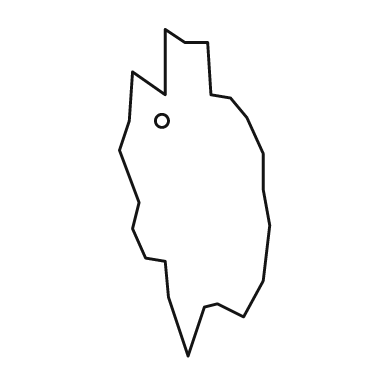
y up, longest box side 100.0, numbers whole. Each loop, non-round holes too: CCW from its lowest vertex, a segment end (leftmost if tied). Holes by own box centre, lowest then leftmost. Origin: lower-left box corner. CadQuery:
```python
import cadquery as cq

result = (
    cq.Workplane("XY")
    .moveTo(21.0, 0.0)
    .lineTo(26.0, 15.0)
    .lineTo(30.0, 16.0)
    .lineTo(38.0, 12.0)
    .lineTo(44.0, 23.0)
    .lineTo(46.0, 40.0)
    .lineTo(44.0, 51.0)
    .lineTo(44.0, 62.0)
    .lineTo(39.0, 73.0)
    .lineTo(34.0, 79.0)
    .lineTo(28.0, 80.0)
    .lineTo(27.0, 96.0)
    .lineTo(20.0, 96.0)
    .lineTo(14.0, 100.0)
    .lineTo(14.0, 80.0)
    .lineTo(4.0, 87.0)
    .lineTo(3.0, 72.0)
    .lineTo(0.0, 63.0)
    .lineTo(6.0, 47.0)
    .lineTo(4.0, 39.0)
    .lineTo(8.0, 30.0)
    .lineTo(14.0, 29.0)
    .lineTo(15.0, 18.0)
    .close()
    .moveTo(13.0, 72.0)
    .circle(2.0)
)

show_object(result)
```